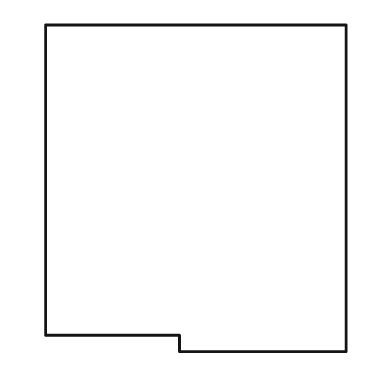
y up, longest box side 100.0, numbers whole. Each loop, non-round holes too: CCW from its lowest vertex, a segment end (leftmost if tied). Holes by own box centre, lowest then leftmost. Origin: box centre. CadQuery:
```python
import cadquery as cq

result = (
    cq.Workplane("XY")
    .moveTo(-5.0, -50.0)
    .lineTo(46.0, -50.0)
    .lineTo(46.0, 50.0)
    .lineTo(-46.0, 50.0)
    .lineTo(-46.0, -45.0)
    .lineTo(-5.0, -45.0)
    .close()
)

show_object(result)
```